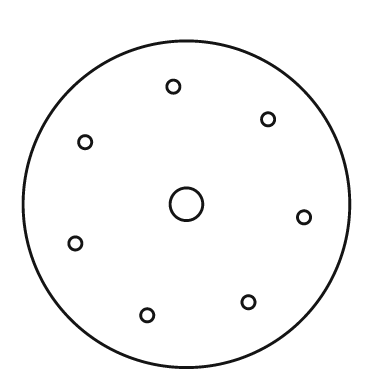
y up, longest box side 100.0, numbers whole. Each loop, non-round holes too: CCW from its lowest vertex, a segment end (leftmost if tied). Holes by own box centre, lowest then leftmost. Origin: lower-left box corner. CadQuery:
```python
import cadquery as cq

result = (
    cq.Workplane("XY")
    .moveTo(50.0, 50.0)
    .circle(50.0)
    .moveTo(38.0, 16.0)
    .circle(2.0)
    .moveTo(69.0, 20.0)
    .circle(2.0)
    .moveTo(16.0, 38.0)
    .circle(2.0)
    .moveTo(86.0, 46.0)
    .circle(2.0)
    .moveTo(50.0, 50.0)
    .circle(5.0)
    .moveTo(19.0, 69.0)
    .circle(2.0)
    .moveTo(75.0, 76.0)
    .circle(2.0)
    .moveTo(46.0, 86.0)
    .circle(2.0)
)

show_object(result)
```